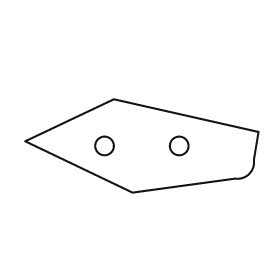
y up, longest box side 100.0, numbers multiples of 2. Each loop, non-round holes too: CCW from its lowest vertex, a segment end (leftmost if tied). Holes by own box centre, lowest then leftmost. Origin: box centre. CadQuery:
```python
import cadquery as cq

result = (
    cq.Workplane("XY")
    .moveTo(-4.0, -20.0)
    .lineTo(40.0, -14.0)
    .threePointArc((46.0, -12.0), (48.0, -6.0))
    .lineTo(50.0, 6.0)
    .lineTo(-12.0, 20.0)
    .lineTo(-50.0, 2.0)
    .close()
    .moveTo(-16.0, 0.0)
    .circle(4.0)
    .moveTo(16.0, 0.0)
    .circle(4.0)
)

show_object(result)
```